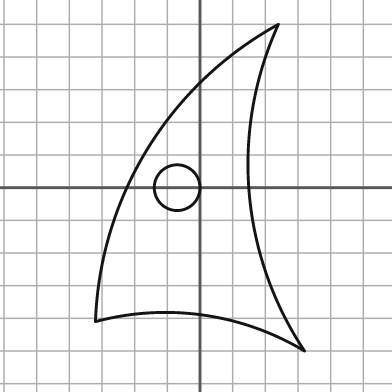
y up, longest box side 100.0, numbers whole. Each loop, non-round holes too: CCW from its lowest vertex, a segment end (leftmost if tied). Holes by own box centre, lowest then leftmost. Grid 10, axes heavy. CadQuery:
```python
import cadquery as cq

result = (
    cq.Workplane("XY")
    .moveTo(32.0, -50.0)
    .threePointArc((15.0, -1.0), (24.0, 50.0))
    .threePointArc((-16.0, 12.0), (-32.0, -41.0))
    .threePointArc((1.0, -39.0), (32.0, -50.0))
    .close()
    .moveTo(-7.0, 0.0)
    .circle(7.0)
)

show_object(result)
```